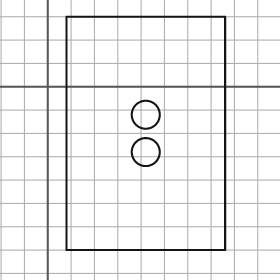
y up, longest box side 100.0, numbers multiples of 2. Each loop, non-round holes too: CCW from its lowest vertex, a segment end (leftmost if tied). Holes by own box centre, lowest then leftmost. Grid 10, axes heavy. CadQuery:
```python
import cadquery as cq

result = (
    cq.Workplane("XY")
    .moveTo(8.0, -70.0)
    .lineTo(76.0, -70.0)
    .lineTo(76.0, 30.0)
    .lineTo(8.0, 30.0)
    .close()
    .moveTo(42.0, -28.0)
    .circle(6.0)
    .moveTo(42.0, -12.0)
    .circle(6.0)
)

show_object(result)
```